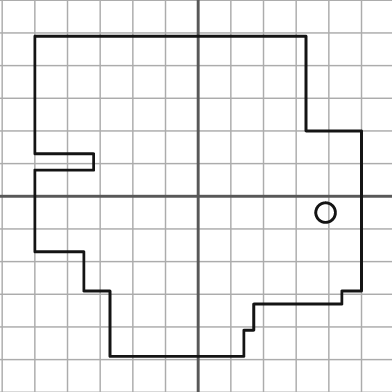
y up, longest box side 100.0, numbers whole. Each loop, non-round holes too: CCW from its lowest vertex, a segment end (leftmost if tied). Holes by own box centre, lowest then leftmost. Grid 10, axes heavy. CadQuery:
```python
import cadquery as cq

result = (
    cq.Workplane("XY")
    .moveTo(-27.0, -49.0)
    .lineTo(14.0, -49.0)
    .lineTo(14.0, -41.0)
    .lineTo(17.0, -41.0)
    .lineTo(17.0, -33.0)
    .lineTo(44.0, -33.0)
    .lineTo(44.0, -29.0)
    .lineTo(50.0, -29.0)
    .lineTo(50.0, 20.0)
    .lineTo(33.0, 20.0)
    .lineTo(33.0, 49.0)
    .lineTo(-50.0, 49.0)
    .lineTo(-50.0, 13.0)
    .lineTo(-32.0, 13.0)
    .lineTo(-32.0, 8.0)
    .lineTo(-50.0, 8.0)
    .lineTo(-50.0, -17.0)
    .lineTo(-35.0, -17.0)
    .lineTo(-35.0, -29.0)
    .lineTo(-27.0, -29.0)
    .close()
    .moveTo(39.0, -5.0)
    .circle(3.0)
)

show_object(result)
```